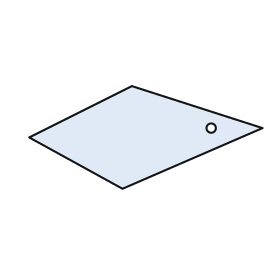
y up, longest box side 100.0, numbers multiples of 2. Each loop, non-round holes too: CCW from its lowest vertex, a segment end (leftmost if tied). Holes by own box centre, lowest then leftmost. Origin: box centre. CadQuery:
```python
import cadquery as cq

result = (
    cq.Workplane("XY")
    .moveTo(-10.0, -22.0)
    .lineTo(50.0, 4.0)
    .lineTo(-6.0, 22.0)
    .lineTo(-50.0, 0.0)
    .close()
    .moveTo(28.0, 4.0)
    .circle(2.0)
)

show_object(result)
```